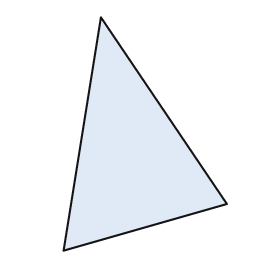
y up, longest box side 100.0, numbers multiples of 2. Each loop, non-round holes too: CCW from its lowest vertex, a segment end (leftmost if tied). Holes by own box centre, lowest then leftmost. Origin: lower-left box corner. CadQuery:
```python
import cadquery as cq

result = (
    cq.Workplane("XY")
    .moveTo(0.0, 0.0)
    .lineTo(70.0, 20.0)
    .lineTo(16.0, 100.0)
    .close()
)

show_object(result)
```